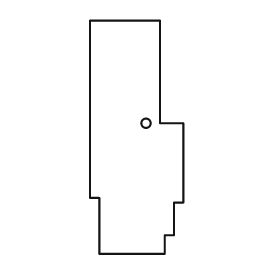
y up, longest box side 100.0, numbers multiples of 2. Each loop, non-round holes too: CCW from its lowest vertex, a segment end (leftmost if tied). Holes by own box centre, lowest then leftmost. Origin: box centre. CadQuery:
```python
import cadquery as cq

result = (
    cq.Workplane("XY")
    .moveTo(-16.0, -50.0)
    .lineTo(12.0, -50.0)
    .lineTo(12.0, -42.0)
    .lineTo(16.0, -42.0)
    .lineTo(16.0, -28.0)
    .lineTo(20.0, -28.0)
    .lineTo(20.0, 6.0)
    .lineTo(10.0, 6.0)
    .lineTo(10.0, 50.0)
    .lineTo(-20.0, 50.0)
    .lineTo(-20.0, -26.0)
    .lineTo(-16.0, -26.0)
    .close()
    .moveTo(4.0, 6.0)
    .circle(2.0)
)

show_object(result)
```